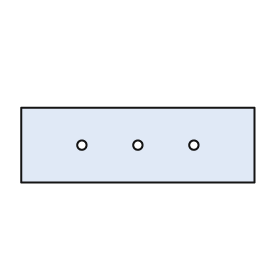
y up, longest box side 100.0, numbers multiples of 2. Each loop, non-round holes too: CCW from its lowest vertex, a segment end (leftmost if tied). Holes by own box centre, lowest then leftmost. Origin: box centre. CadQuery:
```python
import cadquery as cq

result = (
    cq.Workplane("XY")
    .moveTo(-50.0, -16.0)
    .lineTo(50.0, -16.0)
    .lineTo(50.0, 16.0)
    .lineTo(-50.0, 16.0)
    .close()
    .moveTo(-24.0, 0.0)
    .circle(2.0)
    .moveTo(0.0, 0.0)
    .circle(2.0)
    .moveTo(24.0, 0.0)
    .circle(2.0)
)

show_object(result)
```